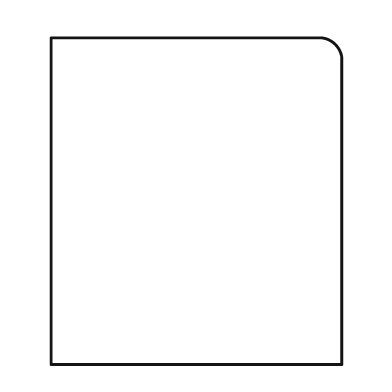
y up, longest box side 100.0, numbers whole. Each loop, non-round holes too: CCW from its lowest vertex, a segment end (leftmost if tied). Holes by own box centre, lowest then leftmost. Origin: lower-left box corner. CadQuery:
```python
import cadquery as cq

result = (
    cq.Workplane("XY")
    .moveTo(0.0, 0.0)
    .lineTo(89.0, 0.0)
    .lineTo(89.0, 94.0)
    .threePointArc((87.0, 98.0), (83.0, 100.0))
    .lineTo(0.0, 100.0)
    .close()
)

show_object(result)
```